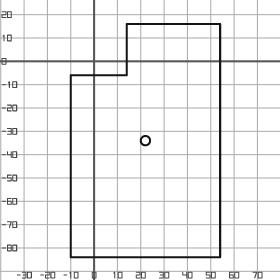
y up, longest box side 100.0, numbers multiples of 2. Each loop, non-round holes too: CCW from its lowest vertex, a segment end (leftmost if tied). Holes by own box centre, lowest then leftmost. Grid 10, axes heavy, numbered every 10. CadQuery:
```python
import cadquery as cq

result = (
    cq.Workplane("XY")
    .moveTo(-10.0, -84.0)
    .lineTo(54.0, -84.0)
    .lineTo(54.0, 16.0)
    .lineTo(14.0, 16.0)
    .lineTo(14.0, -6.0)
    .lineTo(-10.0, -6.0)
    .close()
    .moveTo(22.0, -34.0)
    .circle(2.0)
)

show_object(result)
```